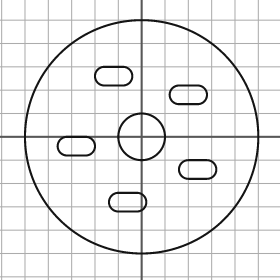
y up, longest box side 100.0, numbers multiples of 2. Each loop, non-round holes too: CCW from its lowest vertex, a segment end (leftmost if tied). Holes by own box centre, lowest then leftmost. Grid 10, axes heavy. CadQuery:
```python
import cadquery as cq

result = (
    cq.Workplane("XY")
    .moveTo(0.0, 0.0)
    .circle(50.0)
    .moveTo(-10.0, -32.0)
    .lineTo(-2.0, -32.0)
    .threePointArc((2.0, -28.0), (-2.0, -24.0))
    .lineTo(-10.0, -24.0)
    .threePointArc((-14.0, -28.0), (-10.0, -32.0))
    .close()
    .moveTo(20.0, -18.0)
    .lineTo(28.0, -18.0)
    .threePointArc((32.0, -14.0), (28.0, -10.0))
    .lineTo(20.0, -10.0)
    .threePointArc((16.0, -14.0), (20.0, -18.0))
    .close()
    .moveTo(-32.0, -8.0)
    .lineTo(-24.0, -8.0)
    .threePointArc((-20.0, -4.0), (-24.0, 0.0))
    .lineTo(-32.0, 0.0)
    .threePointArc((-36.0, -4.0), (-32.0, -8.0))
    .close()
    .moveTo(0.0, 0.0)
    .circle(10.0)
    .moveTo(16.0, 14.0)
    .lineTo(24.0, 14.0)
    .threePointArc((28.0, 18.0), (24.0, 22.0))
    .lineTo(16.0, 22.0)
    .threePointArc((12.0, 18.0), (16.0, 14.0))
    .close()
    .moveTo(-16.0, 22.0)
    .lineTo(-8.0, 22.0)
    .threePointArc((-4.0, 26.0), (-8.0, 30.0))
    .lineTo(-16.0, 30.0)
    .threePointArc((-20.0, 26.0), (-16.0, 22.0))
    .close()
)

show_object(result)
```